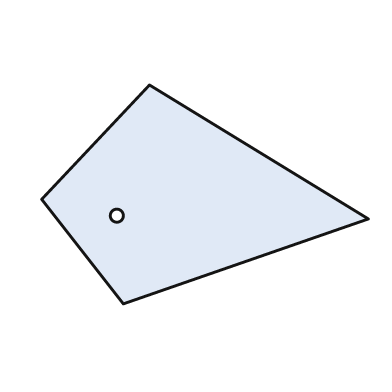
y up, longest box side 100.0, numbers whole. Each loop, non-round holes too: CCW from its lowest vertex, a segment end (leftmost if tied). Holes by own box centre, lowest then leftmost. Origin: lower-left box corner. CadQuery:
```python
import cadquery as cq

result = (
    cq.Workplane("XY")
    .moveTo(25.0, 0.0)
    .lineTo(100.0, 26.0)
    .lineTo(33.0, 67.0)
    .lineTo(0.0, 32.0)
    .close()
    .moveTo(23.0, 27.0)
    .circle(2.0)
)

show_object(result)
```